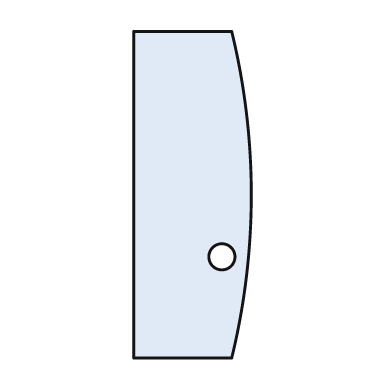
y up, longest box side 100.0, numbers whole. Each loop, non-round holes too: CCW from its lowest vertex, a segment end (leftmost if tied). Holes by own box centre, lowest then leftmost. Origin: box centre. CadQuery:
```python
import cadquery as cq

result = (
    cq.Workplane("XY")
    .moveTo(-18.0, -50.0)
    .lineTo(12.0, -50.0)
    .threePointArc((18.0, 0.0), (12.0, 50.0))
    .lineTo(-18.0, 50.0)
    .close()
    .moveTo(9.0, -19.0)
    .circle(4.0)
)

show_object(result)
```